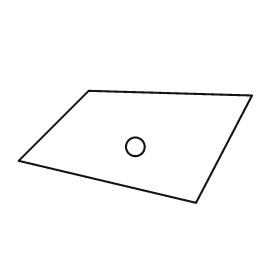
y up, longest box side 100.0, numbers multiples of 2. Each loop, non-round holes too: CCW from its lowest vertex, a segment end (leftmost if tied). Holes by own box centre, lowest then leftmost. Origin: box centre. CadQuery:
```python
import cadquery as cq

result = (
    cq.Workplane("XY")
    .moveTo(26.0, -24.0)
    .lineTo(50.0, 22.0)
    .lineTo(-20.0, 24.0)
    .lineTo(-50.0, -6.0)
    .close()
    .moveTo(0.0, 0.0)
    .circle(4.0)
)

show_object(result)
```